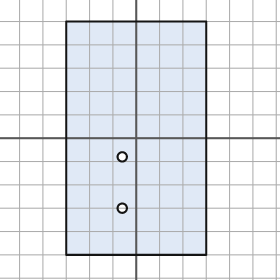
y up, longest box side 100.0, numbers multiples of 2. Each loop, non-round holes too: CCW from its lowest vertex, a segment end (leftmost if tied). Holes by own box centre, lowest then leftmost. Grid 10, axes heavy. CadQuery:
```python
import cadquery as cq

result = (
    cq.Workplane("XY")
    .moveTo(-30.0, -50.0)
    .lineTo(30.0, -50.0)
    .lineTo(30.0, 50.0)
    .lineTo(-30.0, 50.0)
    .close()
    .moveTo(-6.0, -30.0)
    .circle(2.0)
    .moveTo(-6.0, -8.0)
    .circle(2.0)
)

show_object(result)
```